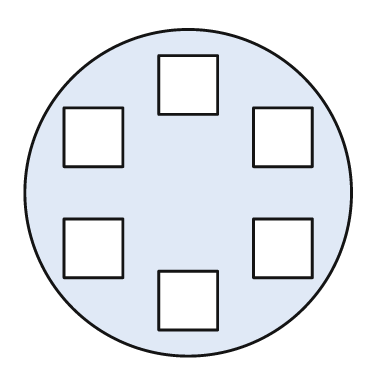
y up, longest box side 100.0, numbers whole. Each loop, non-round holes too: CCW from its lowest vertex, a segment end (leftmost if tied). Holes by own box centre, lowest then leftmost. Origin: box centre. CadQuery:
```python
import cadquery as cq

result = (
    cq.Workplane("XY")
    .moveTo(0.0, 0.0)
    .circle(50.0)
    .moveTo(-9.0, -42.0)
    .lineTo(9.0, -42.0)
    .lineTo(9.0, -24.0)
    .lineTo(-9.0, -24.0)
    .close()
    .moveTo(-38.0, -26.0)
    .lineTo(-20.0, -26.0)
    .lineTo(-20.0, -8.0)
    .lineTo(-38.0, -8.0)
    .close()
    .moveTo(20.0, -26.0)
    .lineTo(38.0, -26.0)
    .lineTo(38.0, -8.0)
    .lineTo(20.0, -8.0)
    .close()
    .moveTo(-38.0, 8.0)
    .lineTo(-20.0, 8.0)
    .lineTo(-20.0, 26.0)
    .lineTo(-38.0, 26.0)
    .close()
    .moveTo(20.0, 8.0)
    .lineTo(38.0, 8.0)
    .lineTo(38.0, 26.0)
    .lineTo(20.0, 26.0)
    .close()
    .moveTo(-9.0, 24.0)
    .lineTo(9.0, 24.0)
    .lineTo(9.0, 42.0)
    .lineTo(-9.0, 42.0)
    .close()
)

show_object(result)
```